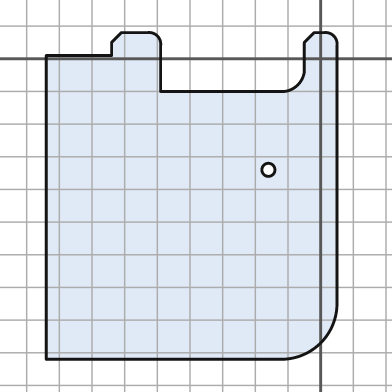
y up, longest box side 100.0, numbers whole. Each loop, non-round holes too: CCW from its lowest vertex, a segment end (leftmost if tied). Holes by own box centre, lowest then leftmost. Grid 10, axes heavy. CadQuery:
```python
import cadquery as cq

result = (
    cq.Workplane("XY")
    .moveTo(-84.0, -92.0)
    .lineTo(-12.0, -92.0)
    .threePointArc((0.0, -87.0), (5.0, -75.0))
    .lineTo(5.0, 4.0)
    .threePointArc((4.0, 7.0), (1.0, 8.0))
    .lineTo(-2.0, 8.0)
    .lineTo(-5.0, 5.0)
    .lineTo(-5.0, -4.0)
    .threePointArc((-7.0, -8.0), (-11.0, -10.0))
    .lineTo(-49.0, -10.0)
    .lineTo(-49.0, 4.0)
    .threePointArc((-50.0, 7.0), (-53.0, 8.0))
    .lineTo(-61.0, 8.0)
    .lineTo(-64.0, 5.0)
    .lineTo(-64.0, 1.0)
    .lineTo(-84.0, 1.0)
    .close()
    .moveTo(-16.0, -34.0)
    .circle(2.0)
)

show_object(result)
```